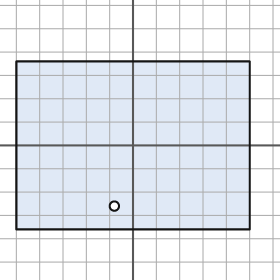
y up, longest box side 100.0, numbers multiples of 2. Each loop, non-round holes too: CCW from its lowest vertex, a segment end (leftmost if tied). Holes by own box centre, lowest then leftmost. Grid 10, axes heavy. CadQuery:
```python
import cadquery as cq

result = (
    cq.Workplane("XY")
    .moveTo(-50.0, -36.0)
    .lineTo(50.0, -36.0)
    .lineTo(50.0, 36.0)
    .lineTo(-50.0, 36.0)
    .close()
    .moveTo(-8.0, -26.0)
    .circle(2.0)
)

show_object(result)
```